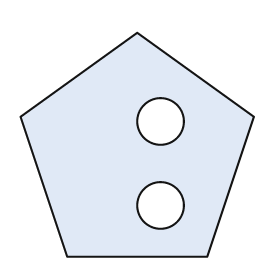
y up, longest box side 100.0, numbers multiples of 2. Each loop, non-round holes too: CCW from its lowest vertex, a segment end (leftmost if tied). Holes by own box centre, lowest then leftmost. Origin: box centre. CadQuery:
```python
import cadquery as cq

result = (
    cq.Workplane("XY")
    .moveTo(-30.0, -48.0)
    .lineTo(30.0, -48.0)
    .lineTo(50.0, 12.0)
    .lineTo(0.0, 48.0)
    .lineTo(-50.0, 12.0)
    .close()
    .moveTo(10.0, -26.0)
    .circle(10.0)
    .moveTo(10.0, 10.0)
    .circle(10.0)
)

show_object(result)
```